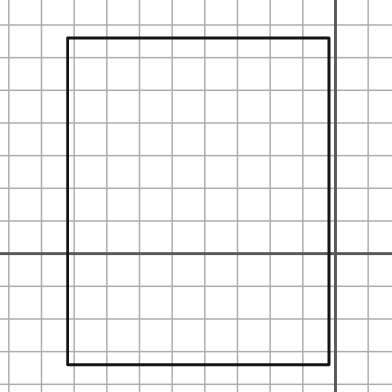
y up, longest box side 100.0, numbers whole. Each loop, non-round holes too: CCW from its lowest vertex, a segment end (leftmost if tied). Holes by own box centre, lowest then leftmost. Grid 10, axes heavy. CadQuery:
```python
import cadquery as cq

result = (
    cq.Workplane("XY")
    .moveTo(-82.0, -34.0)
    .lineTo(-2.0, -34.0)
    .lineTo(-2.0, 66.0)
    .lineTo(-82.0, 66.0)
    .close()
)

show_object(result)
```